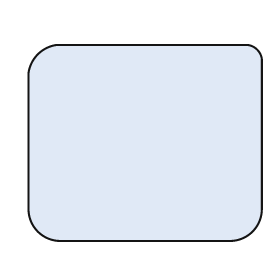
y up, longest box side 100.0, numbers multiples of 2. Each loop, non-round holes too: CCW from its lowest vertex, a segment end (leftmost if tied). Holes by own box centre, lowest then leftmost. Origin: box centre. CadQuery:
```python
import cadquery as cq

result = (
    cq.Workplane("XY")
    .moveTo(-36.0, -42.0)
    .lineTo(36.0, -42.0)
    .threePointArc((46.0, -38.0), (50.0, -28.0))
    .lineTo(50.0, 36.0)
    .threePointArc((48.0, 40.0), (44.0, 42.0))
    .lineTo(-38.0, 42.0)
    .threePointArc((-46.0, 38.0), (-50.0, 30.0))
    .lineTo(-50.0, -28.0)
    .threePointArc((-46.0, -38.0), (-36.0, -42.0))
    .close()
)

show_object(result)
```